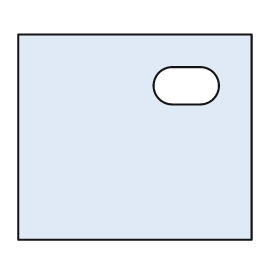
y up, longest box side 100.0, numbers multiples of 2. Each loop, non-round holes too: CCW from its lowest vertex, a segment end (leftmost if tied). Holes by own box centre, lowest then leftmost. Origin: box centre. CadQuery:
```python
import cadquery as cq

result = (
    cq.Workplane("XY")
    .moveTo(-50.0, -44.0)
    .lineTo(50.0, -44.0)
    .lineTo(50.0, 44.0)
    .lineTo(-50.0, 44.0)
    .close()
    .moveTo(16.0, 14.0)
    .lineTo(28.0, 14.0)
    .threePointArc((36.0, 22.0), (28.0, 30.0))
    .lineTo(16.0, 30.0)
    .threePointArc((8.0, 22.0), (16.0, 14.0))
    .close()
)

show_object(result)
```